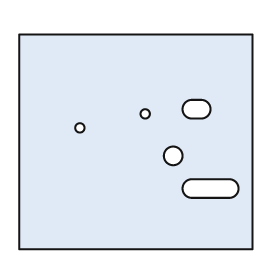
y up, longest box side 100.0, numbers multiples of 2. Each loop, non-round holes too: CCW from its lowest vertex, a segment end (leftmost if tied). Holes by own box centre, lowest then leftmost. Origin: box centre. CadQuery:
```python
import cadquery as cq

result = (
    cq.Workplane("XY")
    .moveTo(-50.0, -46.0)
    .lineTo(50.0, -46.0)
    .lineTo(50.0, 46.0)
    .lineTo(-50.0, 46.0)
    .close()
    .moveTo(24.0, -24.0)
    .lineTo(40.0, -24.0)
    .threePointArc((44.0, -20.0), (40.0, -16.0))
    .lineTo(24.0, -16.0)
    .threePointArc((20.0, -20.0), (24.0, -24.0))
    .close()
    .moveTo(16.0, -6.0)
    .circle(4.0)
    .moveTo(-24.0, 6.0)
    .circle(2.0)
    .moveTo(4.0, 12.0)
    .circle(2.0)
    .moveTo(24.0, 10.0)
    .lineTo(28.0, 10.0)
    .threePointArc((32.0, 14.0), (28.0, 18.0))
    .lineTo(24.0, 18.0)
    .threePointArc((20.0, 14.0), (24.0, 10.0))
    .close()
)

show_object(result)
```